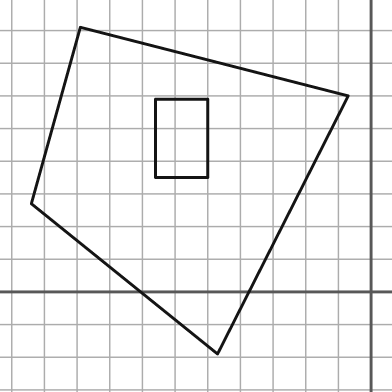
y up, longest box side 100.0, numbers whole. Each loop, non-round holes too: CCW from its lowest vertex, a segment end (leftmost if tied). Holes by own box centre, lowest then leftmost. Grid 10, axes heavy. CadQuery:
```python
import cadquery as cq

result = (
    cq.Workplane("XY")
    .moveTo(-47.0, -19.0)
    .lineTo(-7.0, 60.0)
    .lineTo(-89.0, 81.0)
    .lineTo(-104.0, 27.0)
    .close()
    .moveTo(-66.0, 35.0)
    .lineTo(-50.0, 35.0)
    .lineTo(-50.0, 59.0)
    .lineTo(-66.0, 59.0)
    .close()
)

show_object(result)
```